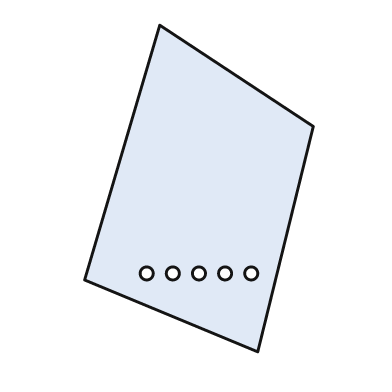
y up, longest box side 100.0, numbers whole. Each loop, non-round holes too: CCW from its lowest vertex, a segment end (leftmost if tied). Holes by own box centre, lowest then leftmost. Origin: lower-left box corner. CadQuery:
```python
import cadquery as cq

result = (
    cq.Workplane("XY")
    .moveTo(53.0, 0.0)
    .lineTo(70.0, 69.0)
    .lineTo(23.0, 100.0)
    .lineTo(0.0, 22.0)
    .close()
    .moveTo(19.0, 24.0)
    .circle(2.0)
    .moveTo(27.0, 24.0)
    .circle(2.0)
    .moveTo(35.0, 24.0)
    .circle(2.0)
    .moveTo(43.0, 24.0)
    .circle(2.0)
    .moveTo(51.0, 24.0)
    .circle(2.0)
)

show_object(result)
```